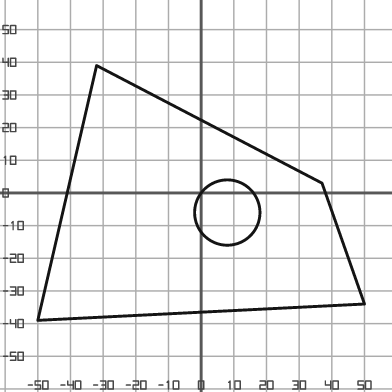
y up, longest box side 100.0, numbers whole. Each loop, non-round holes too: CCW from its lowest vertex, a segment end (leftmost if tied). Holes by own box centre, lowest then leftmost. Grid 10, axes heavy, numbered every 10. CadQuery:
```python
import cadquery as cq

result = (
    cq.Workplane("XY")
    .moveTo(-50.0, -39.0)
    .lineTo(50.0, -34.0)
    .lineTo(37.0, 3.0)
    .lineTo(-32.0, 39.0)
    .close()
    .moveTo(8.0, -6.0)
    .circle(10.0)
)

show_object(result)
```